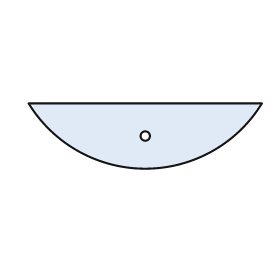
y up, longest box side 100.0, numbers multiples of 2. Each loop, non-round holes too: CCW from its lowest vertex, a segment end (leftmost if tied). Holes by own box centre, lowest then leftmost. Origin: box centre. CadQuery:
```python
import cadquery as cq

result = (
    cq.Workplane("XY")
    .moveTo(-50.0, 14.0)
    .threePointArc((0.0, -14.0), (50.0, 14.0))
    .close()
    .moveTo(0.0, 0.0)
    .circle(2.0)
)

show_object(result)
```